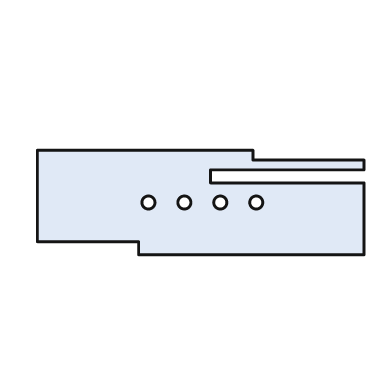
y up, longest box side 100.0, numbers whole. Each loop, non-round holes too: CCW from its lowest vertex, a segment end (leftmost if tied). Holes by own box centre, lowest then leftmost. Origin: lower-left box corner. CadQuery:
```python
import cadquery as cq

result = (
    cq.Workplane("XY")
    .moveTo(31.0, 0.0)
    .lineTo(100.0, 0.0)
    .lineTo(100.0, 22.0)
    .lineTo(53.0, 22.0)
    .lineTo(53.0, 26.0)
    .lineTo(100.0, 26.0)
    .lineTo(100.0, 29.0)
    .lineTo(66.0, 29.0)
    .lineTo(66.0, 32.0)
    .lineTo(0.0, 32.0)
    .lineTo(0.0, 4.0)
    .lineTo(31.0, 4.0)
    .close()
    .moveTo(34.0, 16.0)
    .circle(2.0)
    .moveTo(45.0, 16.0)
    .circle(2.0)
    .moveTo(56.0, 16.0)
    .circle(2.0)
    .moveTo(67.0, 16.0)
    .circle(2.0)
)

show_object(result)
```